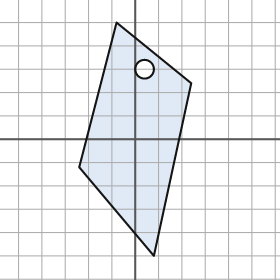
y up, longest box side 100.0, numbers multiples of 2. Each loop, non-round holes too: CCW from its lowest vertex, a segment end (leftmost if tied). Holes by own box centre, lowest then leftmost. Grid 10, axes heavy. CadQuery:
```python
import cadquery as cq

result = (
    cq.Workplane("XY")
    .moveTo(8.0, -50.0)
    .lineTo(24.0, 24.0)
    .lineTo(-8.0, 50.0)
    .lineTo(-24.0, -12.0)
    .close()
    .moveTo(4.0, 30.0)
    .circle(4.0)
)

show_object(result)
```